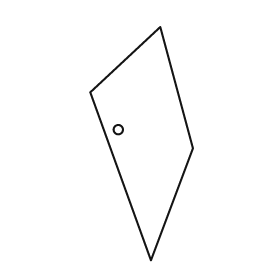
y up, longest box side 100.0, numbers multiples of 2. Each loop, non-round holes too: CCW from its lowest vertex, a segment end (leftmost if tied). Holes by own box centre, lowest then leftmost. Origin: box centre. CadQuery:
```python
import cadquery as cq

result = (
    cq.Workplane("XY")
    .moveTo(4.0, -50.0)
    .lineTo(22.0, -2.0)
    .lineTo(8.0, 50.0)
    .lineTo(-22.0, 22.0)
    .close()
    .moveTo(-10.0, 6.0)
    .circle(2.0)
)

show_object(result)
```